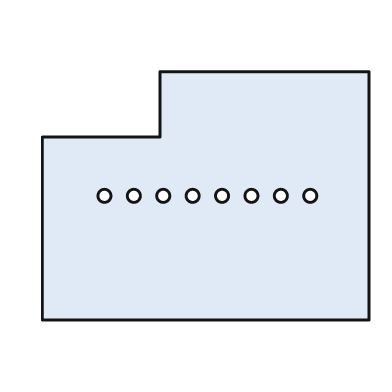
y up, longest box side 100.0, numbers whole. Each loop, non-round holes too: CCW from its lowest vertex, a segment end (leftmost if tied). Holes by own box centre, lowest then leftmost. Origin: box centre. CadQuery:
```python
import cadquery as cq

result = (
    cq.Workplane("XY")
    .moveTo(-50.0, -38.0)
    .lineTo(50.0, -38.0)
    .lineTo(50.0, 38.0)
    .lineTo(-14.0, 38.0)
    .lineTo(-14.0, 18.0)
    .lineTo(-50.0, 18.0)
    .close()
    .moveTo(-31.0, 0.0)
    .circle(2.0)
    .moveTo(-22.0, 0.0)
    .circle(2.0)
    .moveTo(-13.0, 0.0)
    .circle(2.0)
    .moveTo(-4.0, 0.0)
    .circle(2.0)
    .moveTo(5.0, 0.0)
    .circle(2.0)
    .moveTo(14.0, 0.0)
    .circle(2.0)
    .moveTo(23.0, 0.0)
    .circle(2.0)
    .moveTo(32.0, 0.0)
    .circle(2.0)
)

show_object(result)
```